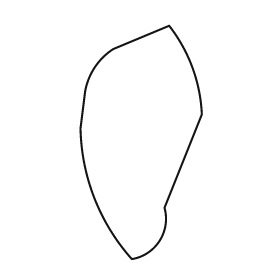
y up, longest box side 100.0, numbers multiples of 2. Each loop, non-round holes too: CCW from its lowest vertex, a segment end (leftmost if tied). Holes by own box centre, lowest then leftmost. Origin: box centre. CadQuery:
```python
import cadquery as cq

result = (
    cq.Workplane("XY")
    .moveTo(-4.0, -50.0)
    .threePointArc((8.0, -42.0), (10.0, -28.0))
    .lineTo(26.0, 12.0)
    .threePointArc((22.0, 32.0), (12.0, 50.0))
    .lineTo(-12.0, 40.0)
    .threePointArc((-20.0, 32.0), (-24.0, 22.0))
    .lineTo(-26.0, 6.0)
    .threePointArc((-20.0, -24.0), (-4.0, -50.0))
    .close()
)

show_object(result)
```